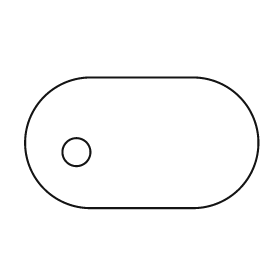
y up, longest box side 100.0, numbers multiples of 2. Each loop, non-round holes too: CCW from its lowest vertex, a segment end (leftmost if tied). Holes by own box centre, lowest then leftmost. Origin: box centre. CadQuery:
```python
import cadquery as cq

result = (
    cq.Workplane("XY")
    .moveTo(-22.0, -28.0)
    .lineTo(22.0, -28.0)
    .threePointArc((50.0, 0.0), (22.0, 28.0))
    .lineTo(-22.0, 28.0)
    .threePointArc((-50.0, 0.0), (-22.0, -28.0))
    .close()
    .moveTo(-28.0, -4.0)
    .circle(6.0)
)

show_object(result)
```